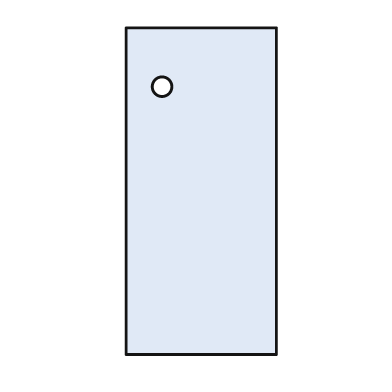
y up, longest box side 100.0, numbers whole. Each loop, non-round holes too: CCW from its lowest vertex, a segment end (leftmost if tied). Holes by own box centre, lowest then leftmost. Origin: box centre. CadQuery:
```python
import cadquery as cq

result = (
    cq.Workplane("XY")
    .moveTo(-23.0, -50.0)
    .lineTo(23.0, -50.0)
    .lineTo(23.0, 50.0)
    .lineTo(-23.0, 50.0)
    .close()
    .moveTo(-12.0, 32.0)
    .circle(3.0)
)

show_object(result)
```